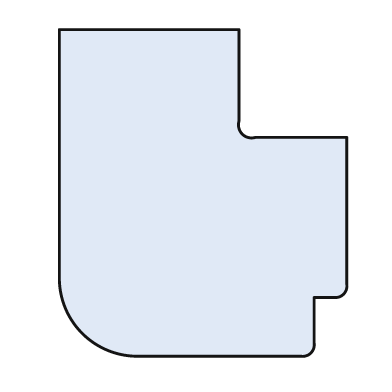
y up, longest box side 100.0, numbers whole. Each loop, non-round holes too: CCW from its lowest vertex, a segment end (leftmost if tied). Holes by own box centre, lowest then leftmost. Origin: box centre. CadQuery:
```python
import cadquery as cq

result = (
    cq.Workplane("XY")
    .moveTo(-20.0, -50.0)
    .lineTo(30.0, -50.0)
    .threePointArc((33.0, -49.0), (34.0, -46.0))
    .lineTo(34.0, -32.0)
    .lineTo(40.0, -32.0)
    .threePointArc((43.0, -31.0), (44.0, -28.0))
    .lineTo(44.0, 17.0)
    .lineTo(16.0, 17.0)
    .threePointArc((12.0, 18.0), (11.0, 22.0))
    .lineTo(11.0, 50.0)
    .lineTo(-44.0, 50.0)
    .lineTo(-44.0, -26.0)
    .threePointArc((-37.0, -43.0), (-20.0, -50.0))
    .close()
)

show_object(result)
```